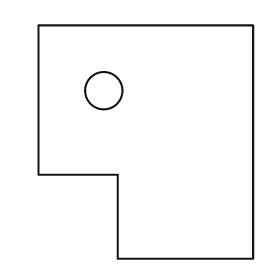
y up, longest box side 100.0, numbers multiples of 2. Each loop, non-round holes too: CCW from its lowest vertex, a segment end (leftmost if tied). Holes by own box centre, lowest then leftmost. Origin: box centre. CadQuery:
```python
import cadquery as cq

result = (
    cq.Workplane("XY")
    .moveTo(-12.0, -50.0)
    .lineTo(46.0, -50.0)
    .lineTo(46.0, 50.0)
    .lineTo(-46.0, 50.0)
    .lineTo(-46.0, -14.0)
    .lineTo(-12.0, -14.0)
    .close()
    .moveTo(-18.0, 22.0)
    .circle(8.0)
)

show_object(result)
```